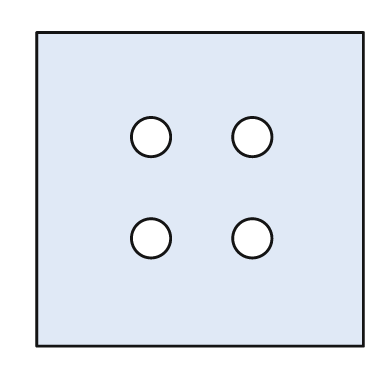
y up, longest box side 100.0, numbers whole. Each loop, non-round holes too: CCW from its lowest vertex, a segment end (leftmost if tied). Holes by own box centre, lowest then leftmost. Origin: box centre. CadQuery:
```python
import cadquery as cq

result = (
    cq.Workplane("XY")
    .moveTo(-50.0, -48.0)
    .lineTo(50.0, -48.0)
    .lineTo(50.0, 48.0)
    .lineTo(-50.0, 48.0)
    .close()
    .moveTo(-15.0, -15.0)
    .circle(6.0)
    .moveTo(16.0, -15.0)
    .circle(6.0)
    .moveTo(-15.0, 16.0)
    .circle(6.0)
    .moveTo(16.0, 16.0)
    .circle(6.0)
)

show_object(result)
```